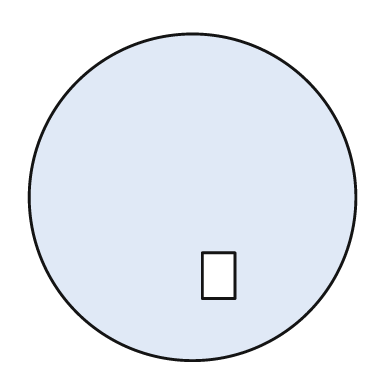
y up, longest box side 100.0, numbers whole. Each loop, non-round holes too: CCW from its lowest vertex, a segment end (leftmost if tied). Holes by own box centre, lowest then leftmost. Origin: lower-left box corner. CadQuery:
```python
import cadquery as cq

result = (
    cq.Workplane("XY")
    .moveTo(50.0, 50.0)
    .circle(50.0)
    .moveTo(53.0, 19.0)
    .lineTo(63.0, 19.0)
    .lineTo(63.0, 33.0)
    .lineTo(53.0, 33.0)
    .close()
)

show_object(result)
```